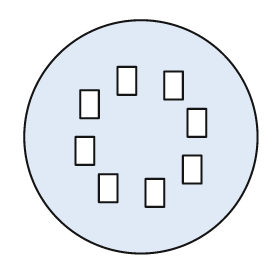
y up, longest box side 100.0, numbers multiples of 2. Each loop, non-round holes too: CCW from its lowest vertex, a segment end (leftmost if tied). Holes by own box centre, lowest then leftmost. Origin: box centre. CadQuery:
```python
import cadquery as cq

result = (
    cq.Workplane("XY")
    .moveTo(0.0, 0.0)
    .circle(50.0)
    .moveTo(2.0, -30.0)
    .lineTo(10.0, -30.0)
    .lineTo(10.0, -18.0)
    .lineTo(2.0, -18.0)
    .close()
    .moveTo(-18.0, -28.0)
    .lineTo(-10.0, -28.0)
    .lineTo(-10.0, -16.0)
    .lineTo(-18.0, -16.0)
    .close()
    .moveTo(18.0, -20.0)
    .lineTo(26.0, -20.0)
    .lineTo(26.0, -8.0)
    .lineTo(18.0, -8.0)
    .close()
    .moveTo(-28.0, -12.0)
    .lineTo(-20.0, -12.0)
    .lineTo(-20.0, 0.0)
    .lineTo(-28.0, 0.0)
    .close()
    .moveTo(20.0, 0.0)
    .lineTo(28.0, 0.0)
    .lineTo(28.0, 12.0)
    .lineTo(20.0, 12.0)
    .close()
    .moveTo(-26.0, 8.0)
    .lineTo(-18.0, 8.0)
    .lineTo(-18.0, 20.0)
    .lineTo(-26.0, 20.0)
    .close()
    .moveTo(10.0, 16.0)
    .lineTo(18.0, 16.0)
    .lineTo(18.0, 28.0)
    .lineTo(10.0, 28.0)
    .close()
    .moveTo(-10.0, 18.0)
    .lineTo(-2.0, 18.0)
    .lineTo(-2.0, 30.0)
    .lineTo(-10.0, 30.0)
    .close()
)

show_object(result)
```